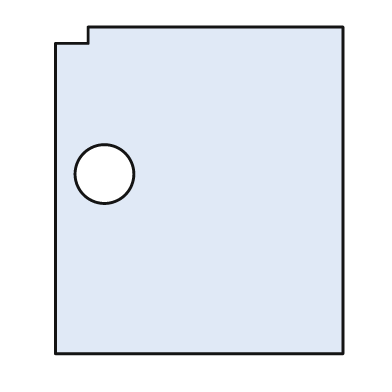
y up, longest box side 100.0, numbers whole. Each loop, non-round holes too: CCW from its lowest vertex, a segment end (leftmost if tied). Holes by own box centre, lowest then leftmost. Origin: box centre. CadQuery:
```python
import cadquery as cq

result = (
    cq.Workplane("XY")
    .moveTo(-44.0, -50.0)
    .lineTo(44.0, -50.0)
    .lineTo(44.0, 50.0)
    .lineTo(-34.0, 50.0)
    .lineTo(-34.0, 45.0)
    .lineTo(-44.0, 45.0)
    .close()
    .moveTo(-29.0, 5.0)
    .circle(9.0)
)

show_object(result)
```